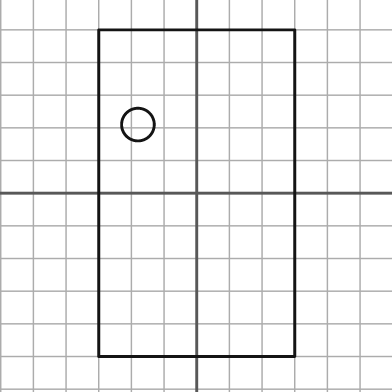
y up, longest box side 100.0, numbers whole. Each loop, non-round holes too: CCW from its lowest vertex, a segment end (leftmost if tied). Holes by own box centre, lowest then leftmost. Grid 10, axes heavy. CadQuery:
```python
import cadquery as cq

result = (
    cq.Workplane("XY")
    .moveTo(-30.0, -50.0)
    .lineTo(30.0, -50.0)
    .lineTo(30.0, 50.0)
    .lineTo(-30.0, 50.0)
    .close()
    .moveTo(-18.0, 21.0)
    .circle(5.0)
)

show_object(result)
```